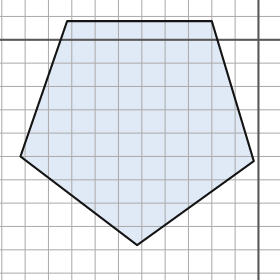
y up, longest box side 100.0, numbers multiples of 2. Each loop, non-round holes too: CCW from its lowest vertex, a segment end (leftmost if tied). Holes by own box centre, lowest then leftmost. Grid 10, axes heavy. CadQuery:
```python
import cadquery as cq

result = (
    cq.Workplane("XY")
    .moveTo(-52.0, -88.0)
    .lineTo(-2.0, -52.0)
    .lineTo(-20.0, 8.0)
    .lineTo(-82.0, 8.0)
    .lineTo(-102.0, -50.0)
    .close()
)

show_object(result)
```